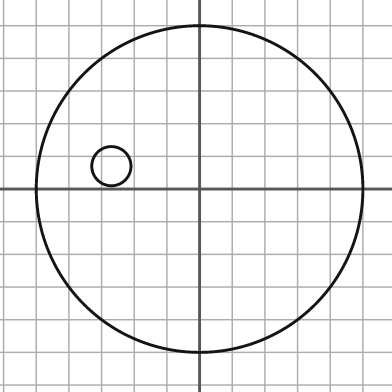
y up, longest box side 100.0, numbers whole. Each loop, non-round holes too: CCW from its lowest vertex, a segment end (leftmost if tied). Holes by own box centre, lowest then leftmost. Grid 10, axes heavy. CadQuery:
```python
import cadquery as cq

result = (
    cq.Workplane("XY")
    .moveTo(0.0, 0.0)
    .circle(50.0)
    .moveTo(-27.0, 7.0)
    .circle(6.0)
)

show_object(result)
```